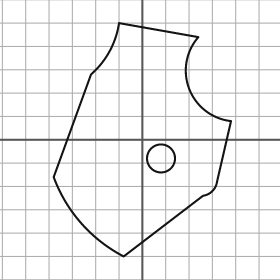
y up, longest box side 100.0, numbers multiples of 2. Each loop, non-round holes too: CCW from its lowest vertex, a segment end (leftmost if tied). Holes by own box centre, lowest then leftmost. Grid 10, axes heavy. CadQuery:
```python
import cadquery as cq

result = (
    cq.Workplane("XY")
    .moveTo(-8.0, -50.0)
    .lineTo(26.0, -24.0)
    .threePointArc((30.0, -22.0), (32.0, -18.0))
    .lineTo(38.0, 8.0)
    .threePointArc((20.0, 22.0), (24.0, 44.0))
    .lineTo(-10.0, 50.0)
    .threePointArc((-14.0, 38.0), (-22.0, 28.0))
    .lineTo(-38.0, -16.0)
    .threePointArc((-26.0, -36.0), (-8.0, -50.0))
    .close()
    .moveTo(8.0, -8.0)
    .circle(6.0)
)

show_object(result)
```